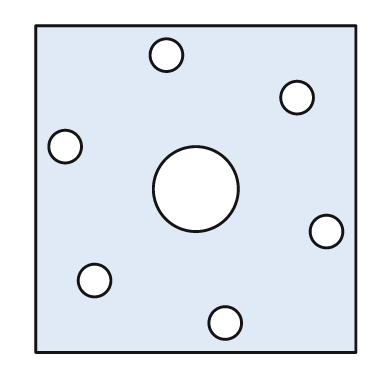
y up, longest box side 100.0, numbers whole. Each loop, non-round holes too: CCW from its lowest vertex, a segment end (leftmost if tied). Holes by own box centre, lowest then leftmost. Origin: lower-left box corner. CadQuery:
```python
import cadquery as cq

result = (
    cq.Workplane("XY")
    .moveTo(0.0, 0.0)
    .lineTo(98.0, 0.0)
    .lineTo(98.0, 100.0)
    .lineTo(0.0, 100.0)
    .close()
    .moveTo(58.0, 9.0)
    .circle(5.0)
    .moveTo(18.0, 22.0)
    .circle(5.0)
    .moveTo(89.0, 37.0)
    .circle(5.0)
    .moveTo(49.0, 50.0)
    .circle(13.0)
    .moveTo(9.0, 63.0)
    .circle(5.0)
    .moveTo(80.0, 78.0)
    .circle(5.0)
    .moveTo(40.0, 91.0)
    .circle(5.0)
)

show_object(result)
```